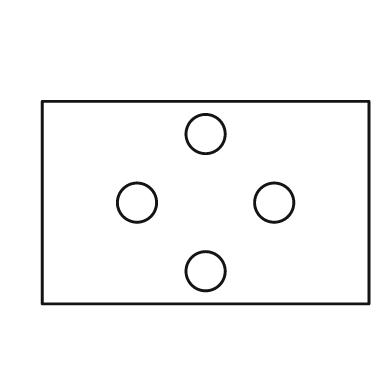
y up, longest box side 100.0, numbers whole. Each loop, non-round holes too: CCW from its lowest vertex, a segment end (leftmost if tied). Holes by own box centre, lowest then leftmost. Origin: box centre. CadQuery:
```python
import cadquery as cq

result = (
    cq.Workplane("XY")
    .moveTo(-50.0, -31.0)
    .lineTo(50.0, -31.0)
    .lineTo(50.0, 31.0)
    .lineTo(-50.0, 31.0)
    .close()
    .moveTo(0.0, -21.0)
    .circle(6.0)
    .moveTo(-21.0, 0.0)
    .circle(6.0)
    .moveTo(21.0, 0.0)
    .circle(6.0)
    .moveTo(0.0, 21.0)
    .circle(6.0)
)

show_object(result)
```